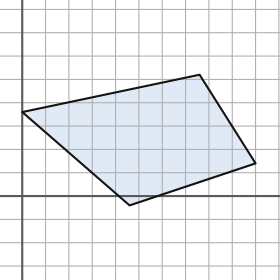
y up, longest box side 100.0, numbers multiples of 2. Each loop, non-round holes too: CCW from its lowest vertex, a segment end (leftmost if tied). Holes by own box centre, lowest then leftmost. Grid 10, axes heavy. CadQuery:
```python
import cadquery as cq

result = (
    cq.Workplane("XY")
    .moveTo(46.0, -4.0)
    .lineTo(100.0, 14.0)
    .lineTo(76.0, 52.0)
    .lineTo(0.0, 36.0)
    .close()
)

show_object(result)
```